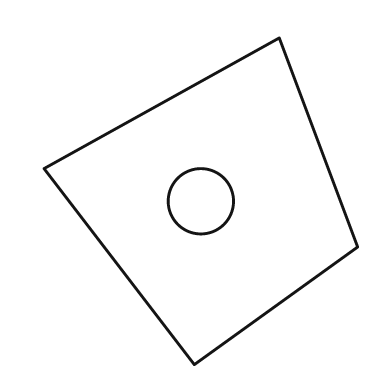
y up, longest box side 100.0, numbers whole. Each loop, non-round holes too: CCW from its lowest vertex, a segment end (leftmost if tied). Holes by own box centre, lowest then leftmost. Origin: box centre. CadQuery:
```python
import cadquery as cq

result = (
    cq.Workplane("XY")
    .moveTo(-2.0, -50.0)
    .lineTo(48.0, -14.0)
    .lineTo(24.0, 50.0)
    .lineTo(-48.0, 10.0)
    .close()
    .moveTo(0.0, 0.0)
    .circle(10.0)
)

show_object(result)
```